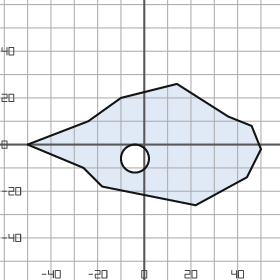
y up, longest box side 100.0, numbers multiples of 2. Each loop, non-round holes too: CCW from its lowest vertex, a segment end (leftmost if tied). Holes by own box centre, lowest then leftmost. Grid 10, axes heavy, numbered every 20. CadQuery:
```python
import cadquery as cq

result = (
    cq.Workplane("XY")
    .moveTo(22.0, -26.0)
    .lineTo(44.0, -14.0)
    .lineTo(50.0, -2.0)
    .lineTo(46.0, 8.0)
    .lineTo(36.0, 12.0)
    .lineTo(14.0, 26.0)
    .lineTo(-10.0, 20.0)
    .lineTo(-24.0, 10.0)
    .lineTo(-50.0, 0.0)
    .lineTo(-26.0, -10.0)
    .lineTo(-18.0, -18.0)
    .close()
    .moveTo(-4.0, -6.0)
    .circle(6.0)
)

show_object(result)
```